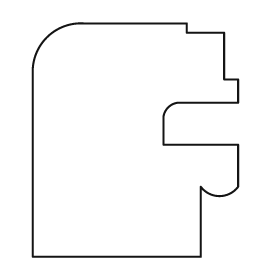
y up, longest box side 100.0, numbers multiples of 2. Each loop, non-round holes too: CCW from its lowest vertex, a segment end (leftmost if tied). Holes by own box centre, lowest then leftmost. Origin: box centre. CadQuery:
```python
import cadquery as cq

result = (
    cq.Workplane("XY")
    .moveTo(-44.0, -50.0)
    .lineTo(28.0, -50.0)
    .lineTo(28.0, -20.0)
    .threePointArc((36.0, -24.0), (44.0, -20.0))
    .lineTo(44.0, -2.0)
    .lineTo(12.0, -2.0)
    .lineTo(12.0, 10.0)
    .threePointArc((14.0, 14.0), (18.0, 16.0))
    .lineTo(44.0, 16.0)
    .lineTo(44.0, 26.0)
    .lineTo(38.0, 26.0)
    .lineTo(38.0, 46.0)
    .lineTo(22.0, 46.0)
    .lineTo(22.0, 50.0)
    .lineTo(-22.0, 50.0)
    .threePointArc((-38.0, 44.0), (-44.0, 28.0))
    .close()
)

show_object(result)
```